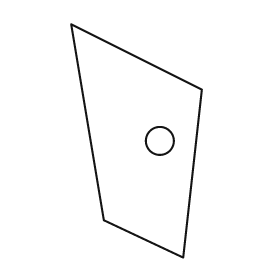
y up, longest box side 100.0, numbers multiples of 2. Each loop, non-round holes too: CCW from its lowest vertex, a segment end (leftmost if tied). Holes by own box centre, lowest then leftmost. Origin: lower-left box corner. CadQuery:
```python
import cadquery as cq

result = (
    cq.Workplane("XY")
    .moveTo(48.0, 0.0)
    .lineTo(56.0, 72.0)
    .lineTo(0.0, 100.0)
    .lineTo(14.0, 16.0)
    .close()
    .moveTo(38.0, 50.0)
    .circle(6.0)
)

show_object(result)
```